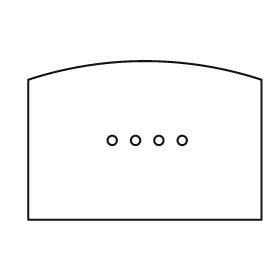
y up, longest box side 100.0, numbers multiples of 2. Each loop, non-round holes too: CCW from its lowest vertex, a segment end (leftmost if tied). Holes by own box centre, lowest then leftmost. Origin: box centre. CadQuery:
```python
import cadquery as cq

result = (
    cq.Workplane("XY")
    .moveTo(-50.0, -34.0)
    .lineTo(50.0, -34.0)
    .lineTo(50.0, 26.0)
    .threePointArc((0.0, 34.0), (-50.0, 26.0))
    .close()
    .moveTo(-14.0, 0.0)
    .circle(2.0)
    .moveTo(-4.0, 0.0)
    .circle(2.0)
    .moveTo(6.0, 0.0)
    .circle(2.0)
    .moveTo(16.0, 0.0)
    .circle(2.0)
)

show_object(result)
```